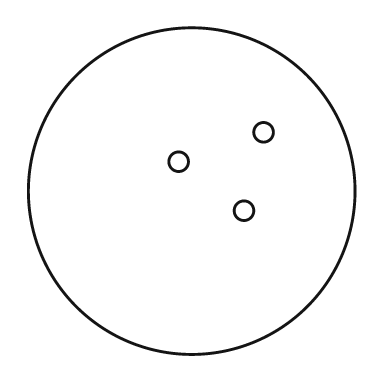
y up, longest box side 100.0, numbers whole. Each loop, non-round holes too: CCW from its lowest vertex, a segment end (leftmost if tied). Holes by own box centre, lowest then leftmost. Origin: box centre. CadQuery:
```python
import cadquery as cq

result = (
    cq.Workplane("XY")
    .moveTo(0.0, 0.0)
    .circle(50.0)
    .moveTo(16.0, -6.0)
    .circle(3.0)
    .moveTo(-4.0, 9.0)
    .circle(3.0)
    .moveTo(22.0, 18.0)
    .circle(3.0)
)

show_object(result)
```